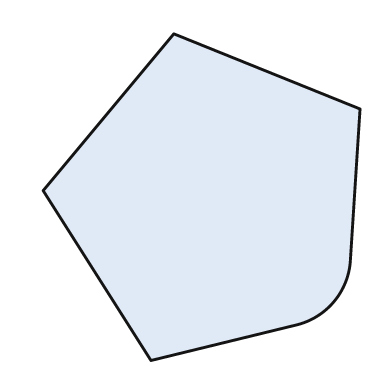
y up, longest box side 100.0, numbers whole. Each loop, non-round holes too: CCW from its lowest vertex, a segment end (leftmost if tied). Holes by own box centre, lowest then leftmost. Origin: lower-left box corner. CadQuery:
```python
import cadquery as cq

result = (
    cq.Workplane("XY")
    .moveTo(33.0, 0.0)
    .lineTo(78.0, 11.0)
    .threePointArc((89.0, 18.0), (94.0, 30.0))
    .lineTo(97.0, 77.0)
    .lineTo(40.0, 100.0)
    .lineTo(0.0, 52.0)
    .close()
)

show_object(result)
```